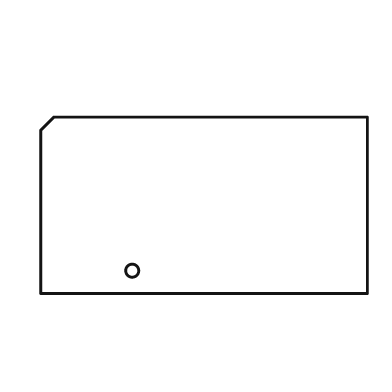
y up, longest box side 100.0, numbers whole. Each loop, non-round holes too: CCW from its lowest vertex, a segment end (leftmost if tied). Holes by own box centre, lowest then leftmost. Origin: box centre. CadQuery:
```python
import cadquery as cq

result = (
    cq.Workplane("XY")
    .moveTo(-50.0, -27.0)
    .lineTo(50.0, -27.0)
    .lineTo(50.0, 27.0)
    .lineTo(-46.0, 27.0)
    .lineTo(-50.0, 23.0)
    .close()
    .moveTo(-22.0, -20.0)
    .circle(2.0)
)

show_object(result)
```